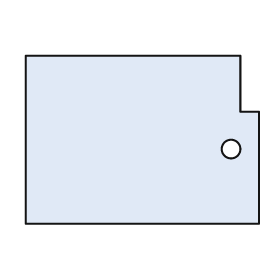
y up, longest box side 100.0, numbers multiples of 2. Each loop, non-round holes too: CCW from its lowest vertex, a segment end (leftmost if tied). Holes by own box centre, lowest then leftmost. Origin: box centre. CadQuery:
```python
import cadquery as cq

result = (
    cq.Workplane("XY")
    .moveTo(-50.0, -36.0)
    .lineTo(50.0, -36.0)
    .lineTo(50.0, 12.0)
    .lineTo(42.0, 12.0)
    .lineTo(42.0, 36.0)
    .lineTo(-50.0, 36.0)
    .close()
    .moveTo(38.0, -4.0)
    .circle(4.0)
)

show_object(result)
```